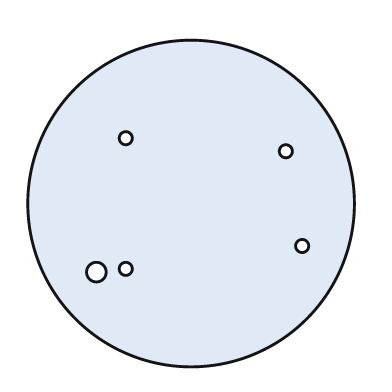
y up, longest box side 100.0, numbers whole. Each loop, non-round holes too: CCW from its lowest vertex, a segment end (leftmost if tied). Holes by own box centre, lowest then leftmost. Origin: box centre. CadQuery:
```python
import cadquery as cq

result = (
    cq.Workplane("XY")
    .moveTo(0.0, 0.0)
    .circle(50.0)
    .moveTo(-29.0, -21.0)
    .circle(3.0)
    .moveTo(-20.0, -20.0)
    .circle(2.0)
    .moveTo(34.0, -13.0)
    .circle(2.0)
    .moveTo(29.0, 16.0)
    .circle(2.0)
    .moveTo(-20.0, 20.0)
    .circle(2.0)
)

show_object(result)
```